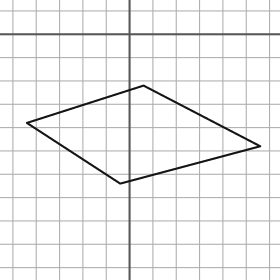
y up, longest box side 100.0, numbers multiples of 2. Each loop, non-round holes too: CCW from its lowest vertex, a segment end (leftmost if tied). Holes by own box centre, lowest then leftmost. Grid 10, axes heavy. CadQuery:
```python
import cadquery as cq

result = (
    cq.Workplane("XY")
    .moveTo(-4.0, -64.0)
    .lineTo(56.0, -48.0)
    .lineTo(6.0, -22.0)
    .lineTo(-44.0, -38.0)
    .close()
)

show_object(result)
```